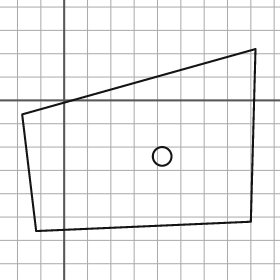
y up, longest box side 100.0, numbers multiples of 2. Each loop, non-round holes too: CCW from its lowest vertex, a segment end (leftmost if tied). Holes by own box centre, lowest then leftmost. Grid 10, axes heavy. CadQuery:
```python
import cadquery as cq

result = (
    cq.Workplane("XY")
    .moveTo(-12.0, -56.0)
    .lineTo(80.0, -52.0)
    .lineTo(82.0, 22.0)
    .lineTo(-18.0, -6.0)
    .close()
    .moveTo(42.0, -24.0)
    .circle(4.0)
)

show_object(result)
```